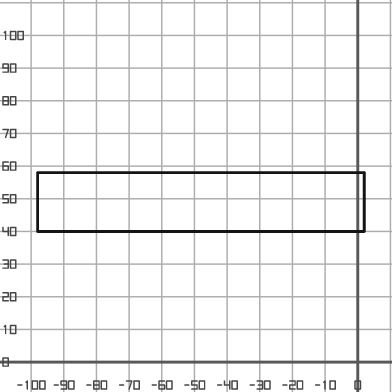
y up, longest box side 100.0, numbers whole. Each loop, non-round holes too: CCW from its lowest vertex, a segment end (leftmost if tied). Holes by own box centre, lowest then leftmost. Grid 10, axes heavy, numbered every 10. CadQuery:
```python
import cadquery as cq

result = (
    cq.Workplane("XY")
    .moveTo(-98.0, 40.0)
    .lineTo(2.0, 40.0)
    .lineTo(2.0, 58.0)
    .lineTo(-98.0, 58.0)
    .close()
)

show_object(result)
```